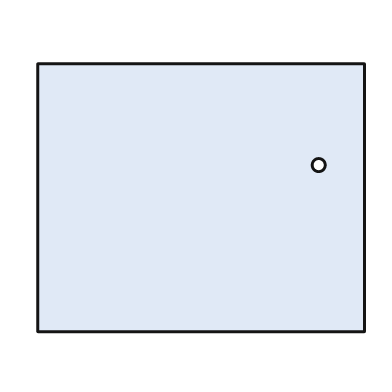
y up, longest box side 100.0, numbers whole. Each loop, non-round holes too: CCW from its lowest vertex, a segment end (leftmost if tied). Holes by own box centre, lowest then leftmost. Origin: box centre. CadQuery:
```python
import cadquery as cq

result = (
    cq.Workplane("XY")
    .moveTo(-50.0, -41.0)
    .lineTo(50.0, -41.0)
    .lineTo(50.0, 41.0)
    .lineTo(-50.0, 41.0)
    .close()
    .moveTo(36.0, 10.0)
    .circle(2.0)
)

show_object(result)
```